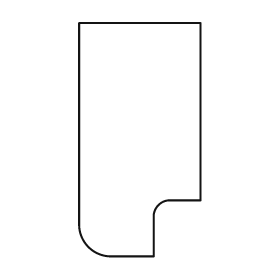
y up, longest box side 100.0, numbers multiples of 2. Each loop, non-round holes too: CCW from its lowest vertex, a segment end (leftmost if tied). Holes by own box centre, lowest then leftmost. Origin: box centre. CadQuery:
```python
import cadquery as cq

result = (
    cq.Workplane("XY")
    .moveTo(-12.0, -50.0)
    .lineTo(6.0, -50.0)
    .lineTo(6.0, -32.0)
    .threePointArc((8.0, -28.0), (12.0, -26.0))
    .lineTo(26.0, -26.0)
    .lineTo(26.0, 50.0)
    .lineTo(-26.0, 50.0)
    .lineTo(-26.0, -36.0)
    .threePointArc((-22.0, -46.0), (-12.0, -50.0))
    .close()
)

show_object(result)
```